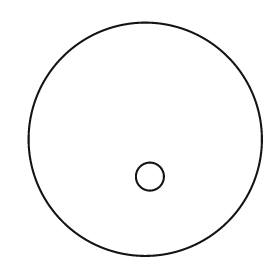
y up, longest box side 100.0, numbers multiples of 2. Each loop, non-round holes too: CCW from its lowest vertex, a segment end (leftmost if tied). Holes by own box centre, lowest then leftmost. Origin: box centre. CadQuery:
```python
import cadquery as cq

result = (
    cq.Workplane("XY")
    .moveTo(0.0, 0.0)
    .circle(50.0)
    .moveTo(2.0, -16.0)
    .circle(6.0)
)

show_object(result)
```